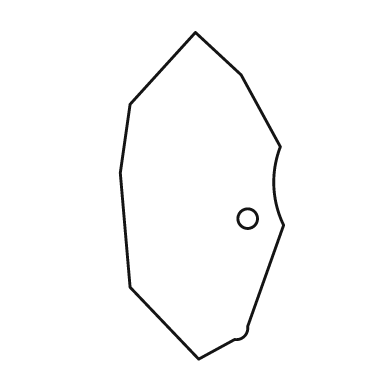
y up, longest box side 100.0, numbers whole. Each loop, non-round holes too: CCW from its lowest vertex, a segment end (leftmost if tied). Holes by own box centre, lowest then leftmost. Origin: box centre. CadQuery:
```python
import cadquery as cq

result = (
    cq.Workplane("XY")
    .moveTo(-1.0, -50.0)
    .lineTo(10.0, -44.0)
    .threePointArc((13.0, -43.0), (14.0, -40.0))
    .lineTo(25.0, -9.0)
    .threePointArc((22.0, 3.0), (24.0, 15.0))
    .lineTo(12.0, 37.0)
    .lineTo(-2.0, 50.0)
    .lineTo(-22.0, 28.0)
    .lineTo(-25.0, 7.0)
    .lineTo(-22.0, -28.0)
    .close()
    .moveTo(14.0, -7.0)
    .circle(3.0)
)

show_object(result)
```